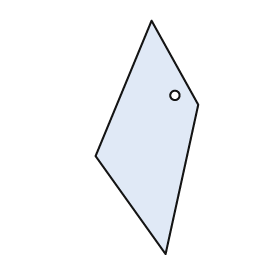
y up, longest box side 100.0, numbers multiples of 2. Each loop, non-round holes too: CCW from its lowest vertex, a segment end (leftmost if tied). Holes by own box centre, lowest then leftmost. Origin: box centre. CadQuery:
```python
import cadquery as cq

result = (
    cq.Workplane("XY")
    .moveTo(8.0, -50.0)
    .lineTo(22.0, 14.0)
    .lineTo(2.0, 50.0)
    .lineTo(-22.0, -8.0)
    .close()
    .moveTo(12.0, 18.0)
    .circle(2.0)
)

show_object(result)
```